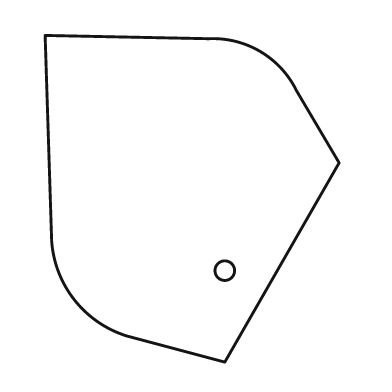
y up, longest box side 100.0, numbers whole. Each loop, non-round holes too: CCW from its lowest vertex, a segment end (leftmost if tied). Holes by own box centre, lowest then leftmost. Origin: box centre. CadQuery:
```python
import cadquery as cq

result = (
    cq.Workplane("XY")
    .moveTo(10.0, -50.0)
    .lineTo(45.0, 11.0)
    .lineTo(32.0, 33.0)
    .threePointArc((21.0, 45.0), (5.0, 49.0))
    .lineTo(-45.0, 50.0)
    .lineTo(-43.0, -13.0)
    .threePointArc((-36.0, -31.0), (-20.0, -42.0))
    .close()
    .moveTo(10.0, -22.0)
    .circle(3.0)
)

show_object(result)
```